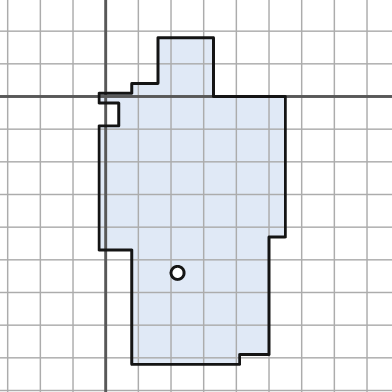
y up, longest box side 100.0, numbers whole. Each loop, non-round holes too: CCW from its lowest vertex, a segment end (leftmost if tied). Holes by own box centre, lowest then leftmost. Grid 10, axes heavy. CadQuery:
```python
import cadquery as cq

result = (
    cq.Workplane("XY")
    .moveTo(8.0, -82.0)
    .lineTo(41.0, -82.0)
    .lineTo(41.0, -79.0)
    .lineTo(50.0, -79.0)
    .lineTo(50.0, -43.0)
    .lineTo(55.0, -43.0)
    .lineTo(55.0, 0.0)
    .lineTo(33.0, 0.0)
    .lineTo(33.0, 18.0)
    .lineTo(16.0, 18.0)
    .lineTo(16.0, 4.0)
    .lineTo(8.0, 4.0)
    .lineTo(8.0, 1.0)
    .lineTo(-2.0, 1.0)
    .lineTo(-2.0, -2.0)
    .lineTo(4.0, -2.0)
    .lineTo(4.0, -9.0)
    .lineTo(-2.0, -9.0)
    .lineTo(-2.0, -47.0)
    .lineTo(8.0, -47.0)
    .close()
    .moveTo(22.0, -54.0)
    .circle(2.0)
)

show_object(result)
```